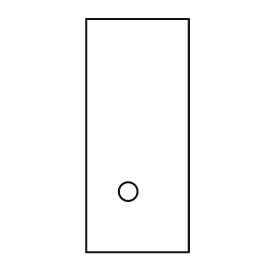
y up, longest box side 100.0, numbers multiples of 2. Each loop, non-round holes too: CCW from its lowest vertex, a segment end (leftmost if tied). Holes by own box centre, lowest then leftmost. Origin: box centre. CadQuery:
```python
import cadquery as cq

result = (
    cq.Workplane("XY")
    .moveTo(-22.0, -50.0)
    .lineTo(22.0, -50.0)
    .lineTo(22.0, 50.0)
    .lineTo(-22.0, 50.0)
    .close()
    .moveTo(-4.0, -24.0)
    .circle(4.0)
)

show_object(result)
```